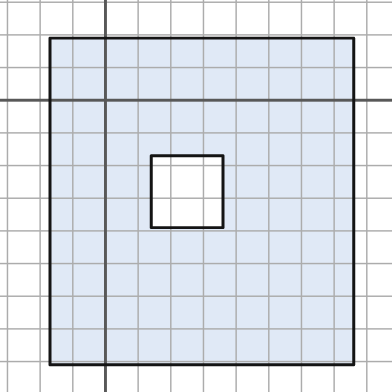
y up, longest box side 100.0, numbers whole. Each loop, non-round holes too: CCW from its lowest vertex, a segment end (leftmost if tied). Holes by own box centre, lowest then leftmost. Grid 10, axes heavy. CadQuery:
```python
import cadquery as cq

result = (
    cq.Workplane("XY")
    .moveTo(-17.0, -81.0)
    .lineTo(76.0, -81.0)
    .lineTo(76.0, 19.0)
    .lineTo(-17.0, 19.0)
    .close()
    .moveTo(14.0, -39.0)
    .lineTo(36.0, -39.0)
    .lineTo(36.0, -17.0)
    .lineTo(14.0, -17.0)
    .close()
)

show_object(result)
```